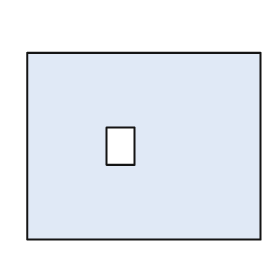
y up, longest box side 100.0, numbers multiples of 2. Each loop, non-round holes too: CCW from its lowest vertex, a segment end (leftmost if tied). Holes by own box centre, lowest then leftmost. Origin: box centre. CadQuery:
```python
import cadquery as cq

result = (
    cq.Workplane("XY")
    .moveTo(-50.0, -40.0)
    .lineTo(50.0, -40.0)
    .lineTo(50.0, 40.0)
    .lineTo(-50.0, 40.0)
    .close()
    .moveTo(-16.0, -8.0)
    .lineTo(-4.0, -8.0)
    .lineTo(-4.0, 8.0)
    .lineTo(-16.0, 8.0)
    .close()
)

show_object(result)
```